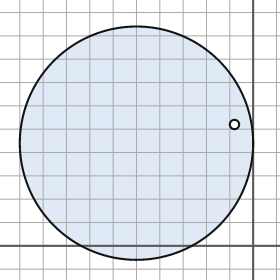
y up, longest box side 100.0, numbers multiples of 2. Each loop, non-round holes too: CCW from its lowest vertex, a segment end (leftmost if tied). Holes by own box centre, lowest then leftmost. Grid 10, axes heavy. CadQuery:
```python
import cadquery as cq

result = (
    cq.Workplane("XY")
    .moveTo(-50.0, 44.0)
    .circle(50.0)
    .moveTo(-8.0, 52.0)
    .circle(2.0)
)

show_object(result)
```